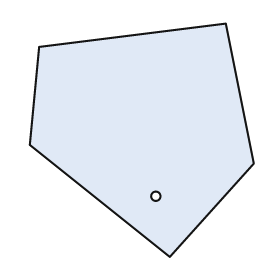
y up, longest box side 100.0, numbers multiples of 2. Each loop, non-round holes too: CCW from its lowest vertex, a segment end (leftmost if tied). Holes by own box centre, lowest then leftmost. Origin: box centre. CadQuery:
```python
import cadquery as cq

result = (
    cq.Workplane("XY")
    .moveTo(12.0, -50.0)
    .lineTo(48.0, -10.0)
    .lineTo(36.0, 50.0)
    .lineTo(-44.0, 40.0)
    .lineTo(-48.0, -2.0)
    .close()
    .moveTo(6.0, -24.0)
    .circle(2.0)
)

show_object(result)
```